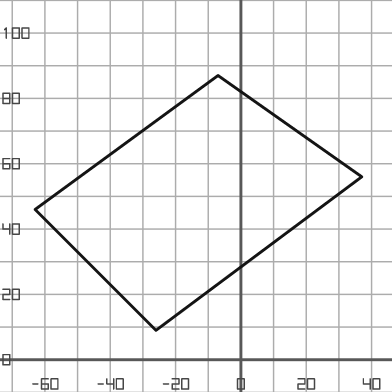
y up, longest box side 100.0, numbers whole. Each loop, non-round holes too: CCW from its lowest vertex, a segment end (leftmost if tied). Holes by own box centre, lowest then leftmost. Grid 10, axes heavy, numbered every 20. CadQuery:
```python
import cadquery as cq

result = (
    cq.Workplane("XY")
    .moveTo(-26.0, 9.0)
    .lineTo(37.0, 56.0)
    .lineTo(-7.0, 87.0)
    .lineTo(-63.0, 46.0)
    .close()
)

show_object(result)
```